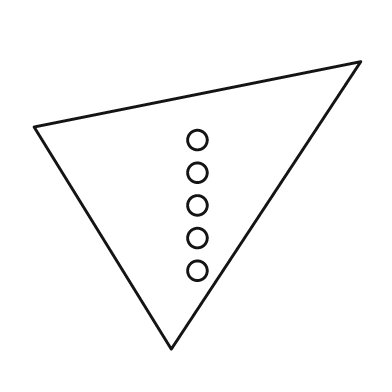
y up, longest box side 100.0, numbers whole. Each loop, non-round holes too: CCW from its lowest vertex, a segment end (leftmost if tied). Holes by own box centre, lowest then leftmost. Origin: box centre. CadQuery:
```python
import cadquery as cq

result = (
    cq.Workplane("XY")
    .moveTo(-8.0, -44.0)
    .lineTo(50.0, 44.0)
    .lineTo(-50.0, 24.0)
    .close()
    .moveTo(0.0, -20.0)
    .circle(3.0)
    .moveTo(0.0, -10.0)
    .circle(3.0)
    .moveTo(0.0, 0.0)
    .circle(3.0)
    .moveTo(0.0, 10.0)
    .circle(3.0)
    .moveTo(0.0, 20.0)
    .circle(3.0)
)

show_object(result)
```